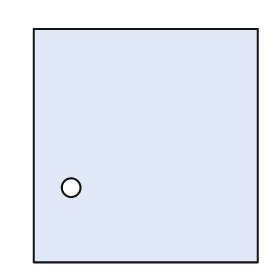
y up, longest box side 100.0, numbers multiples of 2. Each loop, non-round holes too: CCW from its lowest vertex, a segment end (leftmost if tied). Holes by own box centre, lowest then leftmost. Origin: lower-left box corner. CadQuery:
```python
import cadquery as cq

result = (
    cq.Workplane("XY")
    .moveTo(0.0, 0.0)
    .lineTo(96.0, 0.0)
    .lineTo(96.0, 100.0)
    .lineTo(0.0, 100.0)
    .close()
    .moveTo(16.0, 32.0)
    .circle(4.0)
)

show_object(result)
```